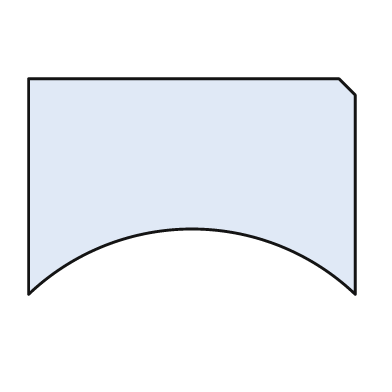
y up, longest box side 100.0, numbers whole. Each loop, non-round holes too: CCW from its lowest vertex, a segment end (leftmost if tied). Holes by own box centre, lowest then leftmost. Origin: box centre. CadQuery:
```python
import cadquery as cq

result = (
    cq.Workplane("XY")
    .moveTo(-50.0, -33.0)
    .threePointArc((0.0, -13.0), (50.0, -33.0))
    .lineTo(50.0, 28.0)
    .lineTo(45.0, 33.0)
    .lineTo(-50.0, 33.0)
    .close()
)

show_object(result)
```